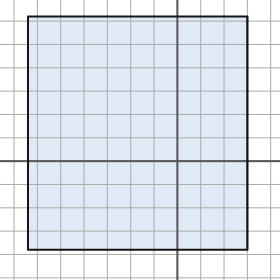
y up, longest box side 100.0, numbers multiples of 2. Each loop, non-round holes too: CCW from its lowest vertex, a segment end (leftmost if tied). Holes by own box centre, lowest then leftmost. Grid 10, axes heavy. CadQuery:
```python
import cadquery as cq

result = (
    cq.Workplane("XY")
    .moveTo(-64.0, -38.0)
    .lineTo(30.0, -38.0)
    .lineTo(30.0, 62.0)
    .lineTo(-64.0, 62.0)
    .close()
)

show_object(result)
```